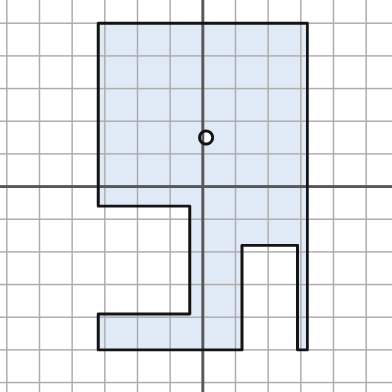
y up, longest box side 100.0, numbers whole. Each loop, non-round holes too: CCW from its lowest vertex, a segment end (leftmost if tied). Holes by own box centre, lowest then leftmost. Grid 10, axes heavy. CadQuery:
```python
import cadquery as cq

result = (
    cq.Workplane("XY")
    .moveTo(-32.0, -50.0)
    .lineTo(12.0, -50.0)
    .lineTo(12.0, -18.0)
    .lineTo(29.0, -18.0)
    .lineTo(29.0, -50.0)
    .lineTo(32.0, -50.0)
    .lineTo(32.0, 50.0)
    .lineTo(-32.0, 50.0)
    .lineTo(-32.0, -6.0)
    .lineTo(-4.0, -6.0)
    .lineTo(-4.0, -39.0)
    .lineTo(-32.0, -39.0)
    .close()
    .moveTo(1.0, 15.0)
    .circle(2.0)
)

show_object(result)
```